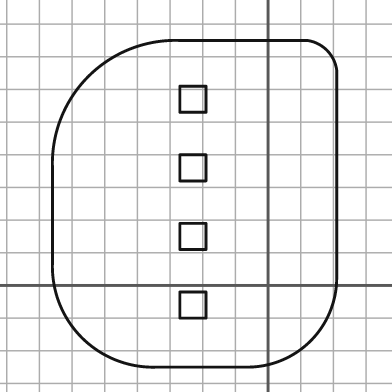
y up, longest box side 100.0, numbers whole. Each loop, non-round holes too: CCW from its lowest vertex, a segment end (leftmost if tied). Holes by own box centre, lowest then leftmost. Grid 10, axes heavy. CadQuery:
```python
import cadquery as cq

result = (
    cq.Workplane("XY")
    .moveTo(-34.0, -25.0)
    .lineTo(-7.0, -25.0)
    .threePointArc((13.0, -17.0), (21.0, 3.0))
    .lineTo(21.0, 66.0)
    .threePointArc((18.0, 72.0), (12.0, 75.0))
    .lineTo(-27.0, 75.0)
    .threePointArc((-55.0, 64.0), (-66.0, 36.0))
    .lineTo(-66.0, 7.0)
    .threePointArc((-57.0, -16.0), (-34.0, -25.0))
    .close()
    .moveTo(-27.0, -10.0)
    .lineTo(-19.0, -10.0)
    .lineTo(-19.0, -2.0)
    .lineTo(-27.0, -2.0)
    .close()
    .moveTo(-27.0, 11.0)
    .lineTo(-19.0, 11.0)
    .lineTo(-19.0, 19.0)
    .lineTo(-27.0, 19.0)
    .close()
    .moveTo(-27.0, 32.0)
    .lineTo(-19.0, 32.0)
    .lineTo(-19.0, 40.0)
    .lineTo(-27.0, 40.0)
    .close()
    .moveTo(-27.0, 53.0)
    .lineTo(-19.0, 53.0)
    .lineTo(-19.0, 61.0)
    .lineTo(-27.0, 61.0)
    .close()
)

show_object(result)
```